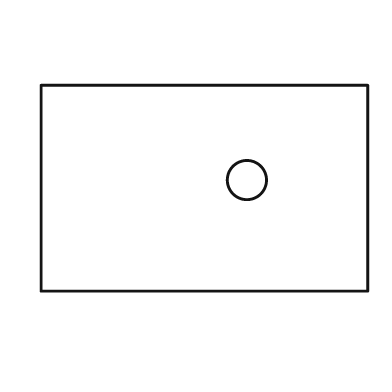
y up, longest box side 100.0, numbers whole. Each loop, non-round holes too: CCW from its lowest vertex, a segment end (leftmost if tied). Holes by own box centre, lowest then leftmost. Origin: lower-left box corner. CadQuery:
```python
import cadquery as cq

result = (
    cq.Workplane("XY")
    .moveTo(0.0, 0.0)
    .lineTo(100.0, 0.0)
    .lineTo(100.0, 63.0)
    .lineTo(0.0, 63.0)
    .close()
    .moveTo(63.0, 34.0)
    .circle(6.0)
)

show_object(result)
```